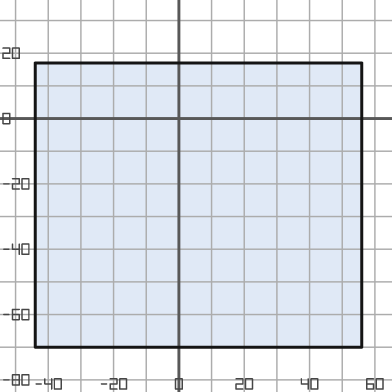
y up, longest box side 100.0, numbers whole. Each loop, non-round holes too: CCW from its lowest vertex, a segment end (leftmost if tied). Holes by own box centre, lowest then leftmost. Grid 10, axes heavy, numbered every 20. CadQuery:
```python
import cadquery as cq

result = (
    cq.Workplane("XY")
    .moveTo(-44.0, -70.0)
    .lineTo(56.0, -70.0)
    .lineTo(56.0, 17.0)
    .lineTo(-44.0, 17.0)
    .close()
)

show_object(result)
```